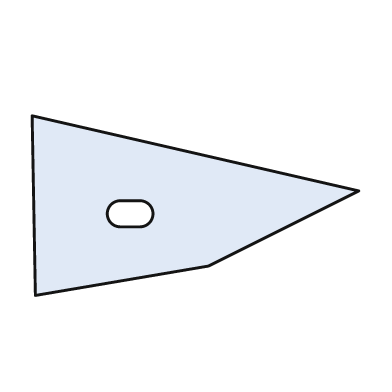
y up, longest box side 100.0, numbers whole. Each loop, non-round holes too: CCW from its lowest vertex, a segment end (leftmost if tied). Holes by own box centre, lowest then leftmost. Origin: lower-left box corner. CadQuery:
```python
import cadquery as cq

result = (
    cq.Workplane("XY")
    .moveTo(1.0, 0.0)
    .lineTo(54.0, 9.0)
    .lineTo(100.0, 32.0)
    .lineTo(0.0, 55.0)
    .close()
    .moveTo(27.0, 21.0)
    .lineTo(33.0, 21.0)
    .threePointArc((37.0, 25.0), (33.0, 29.0))
    .lineTo(27.0, 29.0)
    .threePointArc((23.0, 25.0), (27.0, 21.0))
    .close()
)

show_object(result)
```